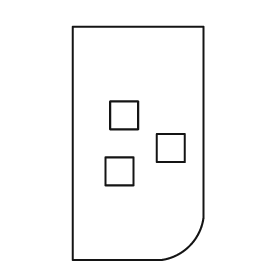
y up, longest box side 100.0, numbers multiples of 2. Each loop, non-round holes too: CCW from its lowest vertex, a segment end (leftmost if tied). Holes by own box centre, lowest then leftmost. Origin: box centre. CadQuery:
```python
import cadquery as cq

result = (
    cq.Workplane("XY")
    .moveTo(-28.0, -50.0)
    .lineTo(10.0, -50.0)
    .threePointArc((22.0, -44.0), (28.0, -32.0))
    .lineTo(28.0, 50.0)
    .lineTo(-28.0, 50.0)
    .close()
    .moveTo(-14.0, -18.0)
    .lineTo(-2.0, -18.0)
    .lineTo(-2.0, -6.0)
    .lineTo(-14.0, -6.0)
    .close()
    .moveTo(8.0, -8.0)
    .lineTo(20.0, -8.0)
    .lineTo(20.0, 4.0)
    .lineTo(8.0, 4.0)
    .close()
    .moveTo(-12.0, 6.0)
    .lineTo(0.0, 6.0)
    .lineTo(0.0, 18.0)
    .lineTo(-12.0, 18.0)
    .close()
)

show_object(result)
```